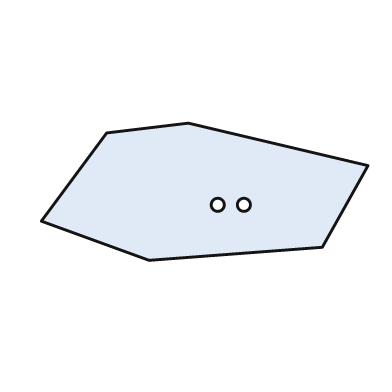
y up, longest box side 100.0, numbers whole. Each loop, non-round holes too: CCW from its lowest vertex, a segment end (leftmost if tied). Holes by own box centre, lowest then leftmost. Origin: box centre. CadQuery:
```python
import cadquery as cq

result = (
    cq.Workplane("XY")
    .moveTo(-17.0, -21.0)
    .lineTo(36.0, -17.0)
    .lineTo(50.0, 8.0)
    .lineTo(-5.0, 21.0)
    .lineTo(-30.0, 18.0)
    .lineTo(-50.0, -9.0)
    .close()
    .moveTo(4.0, -4.0)
    .circle(2.0)
    .moveTo(12.0, -4.0)
    .circle(2.0)
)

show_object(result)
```